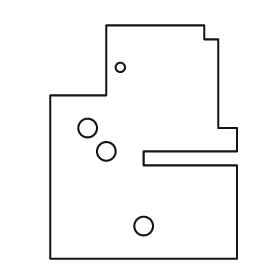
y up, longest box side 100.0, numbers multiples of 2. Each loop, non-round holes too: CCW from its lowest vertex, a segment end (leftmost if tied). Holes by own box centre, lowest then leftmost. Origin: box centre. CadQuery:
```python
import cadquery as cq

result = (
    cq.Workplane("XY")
    .moveTo(-40.0, -50.0)
    .lineTo(40.0, -50.0)
    .lineTo(40.0, -10.0)
    .lineTo(0.0, -10.0)
    .lineTo(0.0, -4.0)
    .lineTo(40.0, -4.0)
    .lineTo(40.0, 6.0)
    .lineTo(32.0, 6.0)
    .lineTo(32.0, 44.0)
    .lineTo(26.0, 44.0)
    .lineTo(26.0, 50.0)
    .lineTo(-16.0, 50.0)
    .lineTo(-16.0, 20.0)
    .lineTo(-40.0, 20.0)
    .close()
    .moveTo(0.0, -36.0)
    .circle(4.0)
    .moveTo(-16.0, -4.0)
    .circle(4.0)
    .moveTo(-24.0, 6.0)
    .circle(4.0)
    .moveTo(-10.0, 32.0)
    .circle(2.0)
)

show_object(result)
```